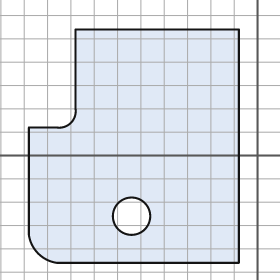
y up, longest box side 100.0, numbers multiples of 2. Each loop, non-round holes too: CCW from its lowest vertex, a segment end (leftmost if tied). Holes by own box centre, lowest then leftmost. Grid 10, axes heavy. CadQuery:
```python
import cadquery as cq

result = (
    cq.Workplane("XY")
    .moveTo(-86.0, -46.0)
    .lineTo(-8.0, -46.0)
    .lineTo(-8.0, 54.0)
    .lineTo(-78.0, 54.0)
    .lineTo(-78.0, 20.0)
    .threePointArc((-80.0, 14.0), (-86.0, 12.0))
    .lineTo(-98.0, 12.0)
    .lineTo(-98.0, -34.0)
    .threePointArc((-94.0, -42.0), (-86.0, -46.0))
    .close()
    .moveTo(-54.0, -26.0)
    .circle(8.0)
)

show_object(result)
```